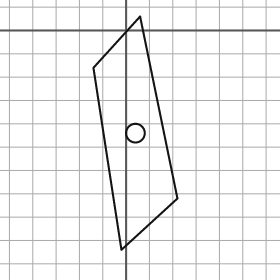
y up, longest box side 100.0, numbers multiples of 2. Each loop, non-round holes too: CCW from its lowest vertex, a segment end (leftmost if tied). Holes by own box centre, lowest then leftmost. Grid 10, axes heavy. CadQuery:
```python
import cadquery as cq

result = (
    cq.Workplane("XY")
    .moveTo(-2.0, -94.0)
    .lineTo(22.0, -72.0)
    .lineTo(6.0, 6.0)
    .lineTo(-14.0, -16.0)
    .close()
    .moveTo(4.0, -44.0)
    .circle(4.0)
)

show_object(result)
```